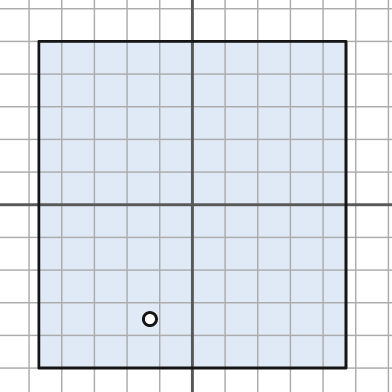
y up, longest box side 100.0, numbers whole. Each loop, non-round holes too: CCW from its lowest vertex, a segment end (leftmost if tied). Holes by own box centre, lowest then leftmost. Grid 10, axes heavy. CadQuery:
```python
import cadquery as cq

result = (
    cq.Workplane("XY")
    .moveTo(-47.0, -50.0)
    .lineTo(47.0, -50.0)
    .lineTo(47.0, 50.0)
    .lineTo(-47.0, 50.0)
    .close()
    .moveTo(-13.0, -35.0)
    .circle(2.0)
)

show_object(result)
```